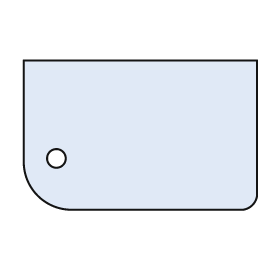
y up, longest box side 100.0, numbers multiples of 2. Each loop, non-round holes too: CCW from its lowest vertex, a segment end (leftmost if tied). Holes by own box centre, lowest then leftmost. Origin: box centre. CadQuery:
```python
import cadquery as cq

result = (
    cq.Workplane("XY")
    .moveTo(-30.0, -32.0)
    .lineTo(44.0, -32.0)
    .threePointArc((48.0, -30.0), (50.0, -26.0))
    .lineTo(50.0, 32.0)
    .lineTo(-50.0, 32.0)
    .lineTo(-50.0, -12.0)
    .threePointArc((-44.0, -26.0), (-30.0, -32.0))
    .close()
    .moveTo(-36.0, -10.0)
    .circle(4.0)
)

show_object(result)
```